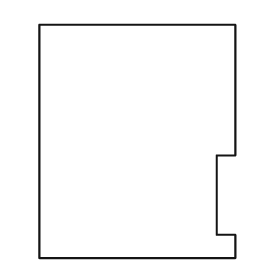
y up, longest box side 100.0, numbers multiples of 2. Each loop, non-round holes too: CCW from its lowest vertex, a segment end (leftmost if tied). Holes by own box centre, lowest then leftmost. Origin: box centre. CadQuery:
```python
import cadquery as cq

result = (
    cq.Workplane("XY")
    .moveTo(-42.0, -50.0)
    .lineTo(42.0, -50.0)
    .lineTo(42.0, -40.0)
    .lineTo(34.0, -40.0)
    .lineTo(34.0, -6.0)
    .lineTo(42.0, -6.0)
    .lineTo(42.0, 50.0)
    .lineTo(-42.0, 50.0)
    .close()
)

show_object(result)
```